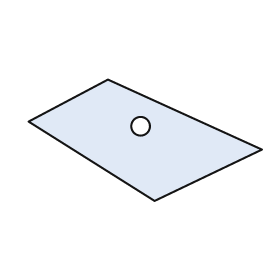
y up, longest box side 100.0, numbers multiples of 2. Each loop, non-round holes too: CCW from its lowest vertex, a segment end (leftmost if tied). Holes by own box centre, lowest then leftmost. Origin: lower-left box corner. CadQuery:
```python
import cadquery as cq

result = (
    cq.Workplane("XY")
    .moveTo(54.0, 0.0)
    .lineTo(100.0, 22.0)
    .lineTo(34.0, 52.0)
    .lineTo(0.0, 34.0)
    .close()
    .moveTo(48.0, 32.0)
    .circle(4.0)
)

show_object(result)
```